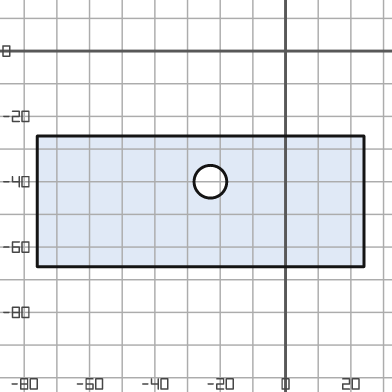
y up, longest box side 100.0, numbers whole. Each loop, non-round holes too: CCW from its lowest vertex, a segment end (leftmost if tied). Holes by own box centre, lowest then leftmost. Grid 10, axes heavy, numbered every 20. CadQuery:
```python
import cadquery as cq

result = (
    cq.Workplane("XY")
    .moveTo(-76.0, -66.0)
    .lineTo(24.0, -66.0)
    .lineTo(24.0, -26.0)
    .lineTo(-76.0, -26.0)
    .close()
    .moveTo(-23.0, -40.0)
    .circle(5.0)
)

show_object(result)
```